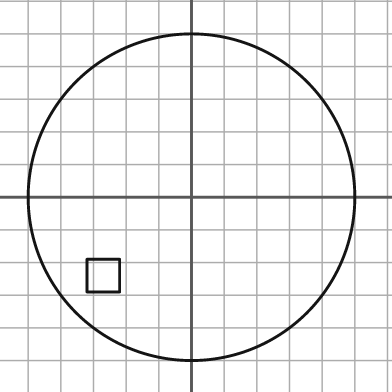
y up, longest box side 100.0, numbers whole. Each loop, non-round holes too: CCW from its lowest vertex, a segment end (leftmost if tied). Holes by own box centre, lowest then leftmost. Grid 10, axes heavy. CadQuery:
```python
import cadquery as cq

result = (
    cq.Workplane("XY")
    .moveTo(0.0, 0.0)
    .circle(50.0)
    .moveTo(-32.0, -29.0)
    .lineTo(-22.0, -29.0)
    .lineTo(-22.0, -19.0)
    .lineTo(-32.0, -19.0)
    .close()
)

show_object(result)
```